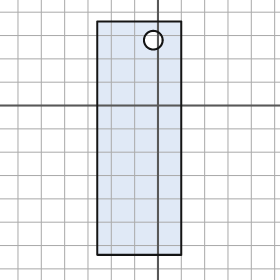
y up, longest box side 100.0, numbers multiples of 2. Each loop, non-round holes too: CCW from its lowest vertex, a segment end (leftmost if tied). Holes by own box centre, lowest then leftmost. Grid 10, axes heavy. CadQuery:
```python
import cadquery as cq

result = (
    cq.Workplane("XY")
    .moveTo(-26.0, -64.0)
    .lineTo(10.0, -64.0)
    .lineTo(10.0, 36.0)
    .lineTo(-26.0, 36.0)
    .close()
    .moveTo(-2.0, 28.0)
    .circle(4.0)
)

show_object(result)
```